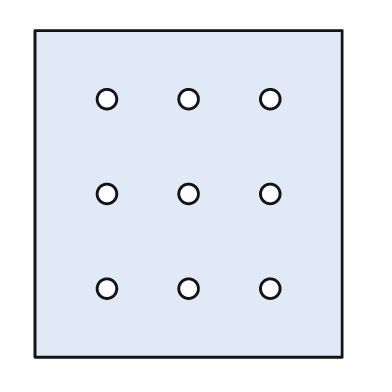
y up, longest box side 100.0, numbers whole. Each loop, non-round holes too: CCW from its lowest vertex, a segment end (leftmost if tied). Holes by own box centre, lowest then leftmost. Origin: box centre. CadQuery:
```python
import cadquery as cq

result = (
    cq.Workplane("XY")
    .moveTo(-47.0, -50.0)
    .lineTo(47.0, -50.0)
    .lineTo(47.0, 50.0)
    .lineTo(-47.0, 50.0)
    .close()
    .moveTo(-25.0, -29.0)
    .circle(3.0)
    .moveTo(0.0, -29.0)
    .circle(3.0)
    .moveTo(25.0, -29.0)
    .circle(3.0)
    .moveTo(-25.0, 0.0)
    .circle(3.0)
    .moveTo(0.0, 0.0)
    .circle(3.0)
    .moveTo(25.0, 0.0)
    .circle(3.0)
    .moveTo(-25.0, 29.0)
    .circle(3.0)
    .moveTo(0.0, 29.0)
    .circle(3.0)
    .moveTo(25.0, 29.0)
    .circle(3.0)
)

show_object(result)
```